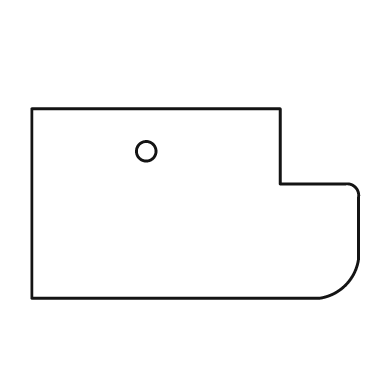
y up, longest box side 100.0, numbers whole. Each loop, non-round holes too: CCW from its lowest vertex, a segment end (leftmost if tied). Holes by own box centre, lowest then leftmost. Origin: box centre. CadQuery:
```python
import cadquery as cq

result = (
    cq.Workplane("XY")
    .moveTo(-50.0, -29.0)
    .lineTo(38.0, -29.0)
    .threePointArc((46.0, -25.0), (50.0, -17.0))
    .lineTo(50.0, 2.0)
    .threePointArc((49.0, 5.0), (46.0, 6.0))
    .lineTo(26.0, 6.0)
    .lineTo(26.0, 29.0)
    .lineTo(-50.0, 29.0)
    .close()
    .moveTo(-15.0, 16.0)
    .circle(3.0)
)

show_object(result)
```